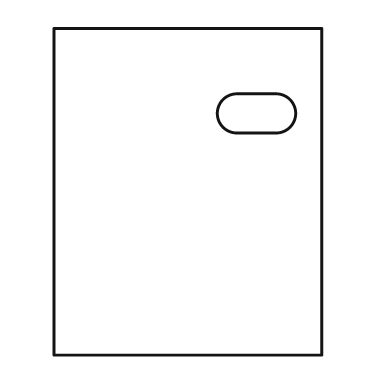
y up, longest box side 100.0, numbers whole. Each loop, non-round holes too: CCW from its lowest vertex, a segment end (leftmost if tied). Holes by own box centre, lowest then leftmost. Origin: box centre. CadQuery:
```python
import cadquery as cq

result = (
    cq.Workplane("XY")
    .moveTo(-41.0, -50.0)
    .lineTo(41.0, -50.0)
    .lineTo(41.0, 50.0)
    .lineTo(-41.0, 50.0)
    .close()
    .moveTo(15.0, 18.0)
    .lineTo(27.0, 18.0)
    .threePointArc((33.0, 24.0), (27.0, 30.0))
    .lineTo(15.0, 30.0)
    .threePointArc((9.0, 24.0), (15.0, 18.0))
    .close()
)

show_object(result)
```